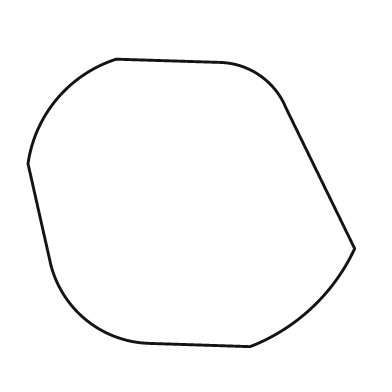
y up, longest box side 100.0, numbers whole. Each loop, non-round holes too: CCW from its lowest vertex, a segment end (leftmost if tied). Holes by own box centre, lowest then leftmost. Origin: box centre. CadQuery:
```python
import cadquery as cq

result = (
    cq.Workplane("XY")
    .moveTo(18.0, -44.0)
    .threePointArc((37.0, -32.0), (50.0, -14.0))
    .lineTo(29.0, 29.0)
    .threePointArc((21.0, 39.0), (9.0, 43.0))
    .lineTo(-23.0, 44.0)
    .threePointArc((-41.0, 32.0), (-50.0, 12.0))
    .lineTo(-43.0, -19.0)
    .threePointArc((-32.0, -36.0), (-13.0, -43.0))
    .close()
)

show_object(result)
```